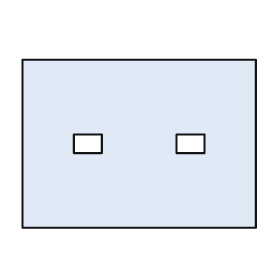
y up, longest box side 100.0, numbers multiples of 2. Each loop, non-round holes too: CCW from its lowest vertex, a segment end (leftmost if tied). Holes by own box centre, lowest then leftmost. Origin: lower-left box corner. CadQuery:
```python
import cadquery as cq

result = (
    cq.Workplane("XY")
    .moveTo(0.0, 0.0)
    .lineTo(100.0, 0.0)
    .lineTo(100.0, 72.0)
    .lineTo(0.0, 72.0)
    .close()
    .moveTo(22.0, 32.0)
    .lineTo(34.0, 32.0)
    .lineTo(34.0, 40.0)
    .lineTo(22.0, 40.0)
    .close()
    .moveTo(66.0, 32.0)
    .lineTo(78.0, 32.0)
    .lineTo(78.0, 40.0)
    .lineTo(66.0, 40.0)
    .close()
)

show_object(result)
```